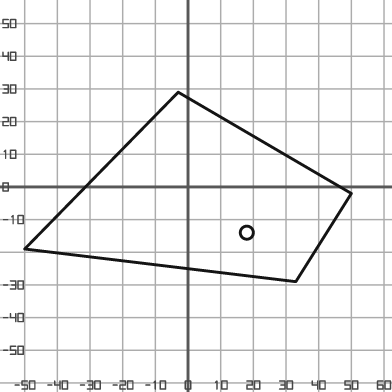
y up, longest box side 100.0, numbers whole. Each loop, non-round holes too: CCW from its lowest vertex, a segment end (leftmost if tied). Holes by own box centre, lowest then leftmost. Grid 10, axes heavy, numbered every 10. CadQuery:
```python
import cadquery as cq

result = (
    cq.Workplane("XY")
    .moveTo(33.0, -29.0)
    .lineTo(50.0, -2.0)
    .lineTo(-3.0, 29.0)
    .lineTo(-50.0, -19.0)
    .close()
    .moveTo(18.0, -14.0)
    .circle(2.0)
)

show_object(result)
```